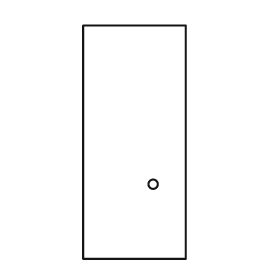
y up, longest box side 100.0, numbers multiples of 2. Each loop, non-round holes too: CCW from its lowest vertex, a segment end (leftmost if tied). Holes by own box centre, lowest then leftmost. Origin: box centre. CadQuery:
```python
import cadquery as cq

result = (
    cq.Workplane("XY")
    .moveTo(-22.0, -50.0)
    .lineTo(22.0, -50.0)
    .lineTo(22.0, 50.0)
    .lineTo(-22.0, 50.0)
    .close()
    .moveTo(8.0, -18.0)
    .circle(2.0)
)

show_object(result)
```